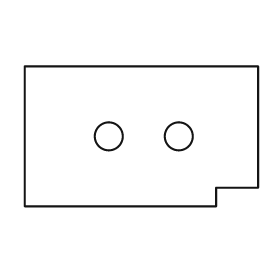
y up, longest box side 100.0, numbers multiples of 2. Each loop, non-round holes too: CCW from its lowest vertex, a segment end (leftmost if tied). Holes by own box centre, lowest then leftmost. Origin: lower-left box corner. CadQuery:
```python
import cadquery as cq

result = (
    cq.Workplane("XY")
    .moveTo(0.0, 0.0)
    .lineTo(82.0, 0.0)
    .lineTo(82.0, 8.0)
    .lineTo(100.0, 8.0)
    .lineTo(100.0, 60.0)
    .lineTo(0.0, 60.0)
    .close()
    .moveTo(36.0, 30.0)
    .circle(6.0)
    .moveTo(66.0, 30.0)
    .circle(6.0)
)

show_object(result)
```